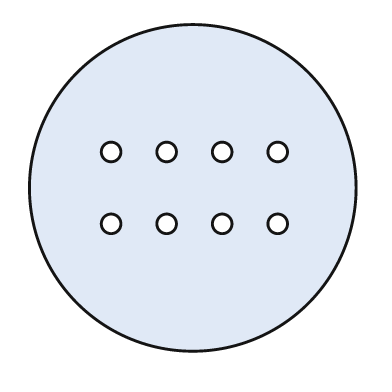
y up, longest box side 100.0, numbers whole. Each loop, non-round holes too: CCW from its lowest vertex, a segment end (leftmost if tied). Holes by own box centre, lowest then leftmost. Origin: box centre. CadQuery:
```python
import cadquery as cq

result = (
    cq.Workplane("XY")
    .moveTo(0.0, 0.0)
    .circle(50.0)
    .moveTo(-25.0, -11.0)
    .circle(3.0)
    .moveTo(-8.0, -11.0)
    .circle(3.0)
    .moveTo(9.0, -11.0)
    .circle(3.0)
    .moveTo(26.0, -11.0)
    .circle(3.0)
    .moveTo(-25.0, 11.0)
    .circle(3.0)
    .moveTo(-8.0, 11.0)
    .circle(3.0)
    .moveTo(9.0, 11.0)
    .circle(3.0)
    .moveTo(26.0, 11.0)
    .circle(3.0)
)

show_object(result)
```